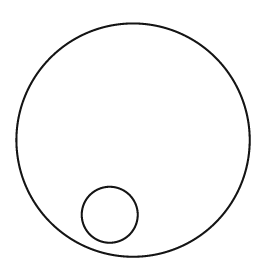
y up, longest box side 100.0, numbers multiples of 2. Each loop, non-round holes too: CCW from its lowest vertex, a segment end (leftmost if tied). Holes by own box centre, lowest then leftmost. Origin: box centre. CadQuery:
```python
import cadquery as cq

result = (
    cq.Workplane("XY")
    .moveTo(0.0, 0.0)
    .circle(50.0)
    .moveTo(-10.0, -32.0)
    .circle(12.0)
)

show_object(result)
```